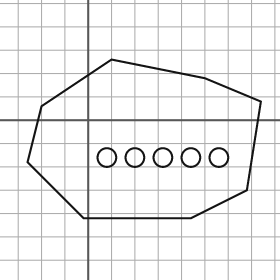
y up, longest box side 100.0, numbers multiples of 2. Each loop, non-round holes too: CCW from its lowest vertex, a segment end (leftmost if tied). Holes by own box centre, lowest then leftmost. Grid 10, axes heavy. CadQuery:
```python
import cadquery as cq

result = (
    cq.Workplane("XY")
    .moveTo(-2.0, -42.0)
    .lineTo(44.0, -42.0)
    .lineTo(68.0, -30.0)
    .lineTo(74.0, 8.0)
    .lineTo(50.0, 18.0)
    .lineTo(10.0, 26.0)
    .lineTo(-20.0, 6.0)
    .lineTo(-26.0, -18.0)
    .close()
    .moveTo(8.0, -16.0)
    .circle(4.0)
    .moveTo(20.0, -16.0)
    .circle(4.0)
    .moveTo(32.0, -16.0)
    .circle(4.0)
    .moveTo(44.0, -16.0)
    .circle(4.0)
    .moveTo(56.0, -16.0)
    .circle(4.0)
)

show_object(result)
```